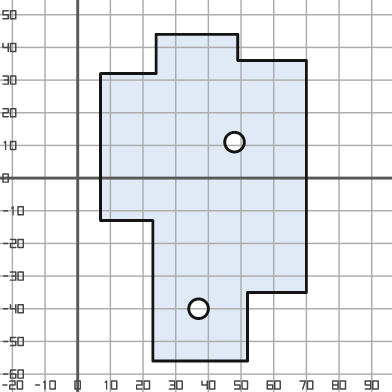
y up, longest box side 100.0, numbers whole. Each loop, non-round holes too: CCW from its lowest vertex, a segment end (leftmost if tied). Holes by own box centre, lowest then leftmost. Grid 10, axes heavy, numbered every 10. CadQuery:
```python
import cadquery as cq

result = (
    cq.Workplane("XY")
    .moveTo(23.0, -56.0)
    .lineTo(52.0, -56.0)
    .lineTo(52.0, -35.0)
    .lineTo(70.0, -35.0)
    .lineTo(70.0, 36.0)
    .lineTo(49.0, 36.0)
    .lineTo(49.0, 44.0)
    .lineTo(24.0, 44.0)
    .lineTo(24.0, 32.0)
    .lineTo(7.0, 32.0)
    .lineTo(7.0, -13.0)
    .lineTo(23.0, -13.0)
    .close()
    .moveTo(37.0, -40.0)
    .circle(3.0)
    .moveTo(48.0, 11.0)
    .circle(3.0)
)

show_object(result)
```